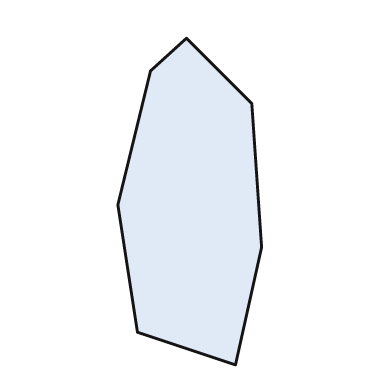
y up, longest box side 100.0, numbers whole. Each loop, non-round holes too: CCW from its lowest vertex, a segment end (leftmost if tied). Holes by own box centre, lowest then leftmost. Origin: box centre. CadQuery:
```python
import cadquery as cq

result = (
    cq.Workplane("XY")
    .moveTo(14.0, -50.0)
    .lineTo(22.0, -14.0)
    .lineTo(19.0, 30.0)
    .lineTo(-1.0, 50.0)
    .lineTo(-12.0, 40.0)
    .lineTo(-22.0, -1.0)
    .lineTo(-16.0, -40.0)
    .close()
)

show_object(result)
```